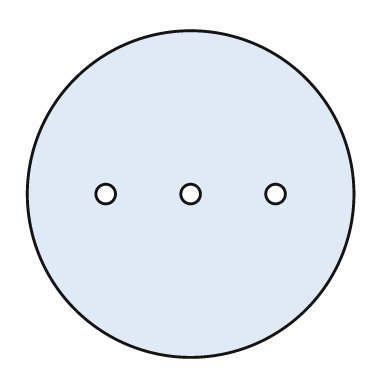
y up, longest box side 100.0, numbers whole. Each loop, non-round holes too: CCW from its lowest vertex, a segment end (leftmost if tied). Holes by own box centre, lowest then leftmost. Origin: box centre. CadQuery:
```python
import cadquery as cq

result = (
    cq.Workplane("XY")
    .moveTo(0.0, 0.0)
    .circle(50.0)
    .moveTo(-26.0, 0.0)
    .circle(3.0)
    .moveTo(0.0, 0.0)
    .circle(3.0)
    .moveTo(26.0, 0.0)
    .circle(3.0)
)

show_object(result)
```